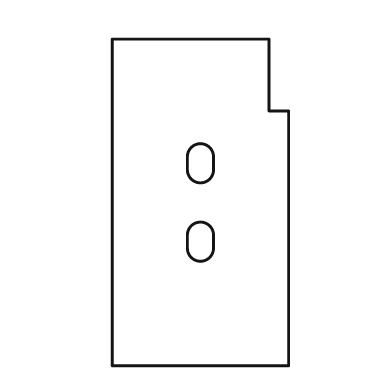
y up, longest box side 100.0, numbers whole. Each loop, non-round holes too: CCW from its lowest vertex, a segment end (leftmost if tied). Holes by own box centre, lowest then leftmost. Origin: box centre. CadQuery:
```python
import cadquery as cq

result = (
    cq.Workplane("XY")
    .moveTo(-27.0, -50.0)
    .lineTo(27.0, -50.0)
    .lineTo(27.0, 28.0)
    .lineTo(21.0, 28.0)
    .lineTo(21.0, 50.0)
    .lineTo(-27.0, 50.0)
    .close()
    .moveTo(-4.0, -14.0)
    .threePointArc((0.0, -18.0), (4.0, -14.0))
    .lineTo(4.0, -10.0)
    .threePointArc((0.0, -6.0), (-4.0, -10.0))
    .close()
    .moveTo(-4.0, 10.0)
    .threePointArc((0.0, 6.0), (4.0, 10.0))
    .lineTo(4.0, 14.0)
    .threePointArc((0.0, 18.0), (-4.0, 14.0))
    .close()
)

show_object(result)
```